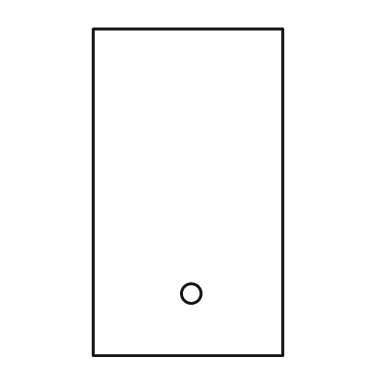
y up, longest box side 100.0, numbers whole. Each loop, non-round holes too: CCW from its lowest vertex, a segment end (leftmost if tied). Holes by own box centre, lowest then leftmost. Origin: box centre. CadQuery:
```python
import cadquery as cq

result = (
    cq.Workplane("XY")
    .moveTo(-29.0, -50.0)
    .lineTo(29.0, -50.0)
    .lineTo(29.0, 50.0)
    .lineTo(-29.0, 50.0)
    .close()
    .moveTo(1.0, -31.0)
    .circle(3.0)
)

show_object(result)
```